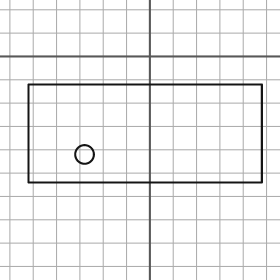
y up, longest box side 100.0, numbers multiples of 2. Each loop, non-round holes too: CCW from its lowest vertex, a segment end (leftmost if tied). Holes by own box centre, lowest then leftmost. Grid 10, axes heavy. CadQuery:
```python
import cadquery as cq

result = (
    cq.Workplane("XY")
    .moveTo(-52.0, -54.0)
    .lineTo(48.0, -54.0)
    .lineTo(48.0, -12.0)
    .lineTo(-52.0, -12.0)
    .close()
    .moveTo(-28.0, -42.0)
    .circle(4.0)
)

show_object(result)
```